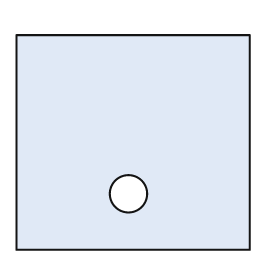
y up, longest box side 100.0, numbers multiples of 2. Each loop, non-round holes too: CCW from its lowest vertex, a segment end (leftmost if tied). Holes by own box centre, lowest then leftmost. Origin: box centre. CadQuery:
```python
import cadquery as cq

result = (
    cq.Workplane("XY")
    .moveTo(-50.0, -46.0)
    .lineTo(50.0, -46.0)
    .lineTo(50.0, 46.0)
    .lineTo(-50.0, 46.0)
    .close()
    .moveTo(-2.0, -22.0)
    .circle(8.0)
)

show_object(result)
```